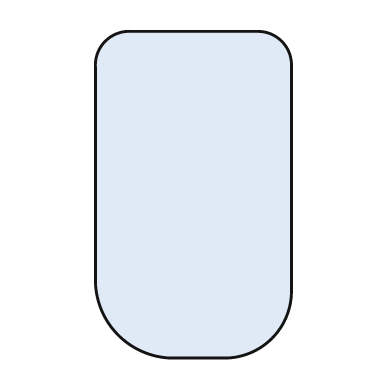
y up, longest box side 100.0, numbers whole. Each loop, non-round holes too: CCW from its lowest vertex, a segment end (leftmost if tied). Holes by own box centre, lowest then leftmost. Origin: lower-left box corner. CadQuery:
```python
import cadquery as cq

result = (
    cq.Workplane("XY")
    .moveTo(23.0, 0.0)
    .lineTo(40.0, 0.0)
    .threePointArc((54.0, 6.0), (60.0, 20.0))
    .lineTo(60.0, 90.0)
    .threePointArc((57.0, 97.0), (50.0, 100.0))
    .lineTo(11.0, 100.0)
    .threePointArc((3.0, 97.0), (0.0, 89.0))
    .lineTo(0.0, 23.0)
    .threePointArc((7.0, 7.0), (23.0, 0.0))
    .close()
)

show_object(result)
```